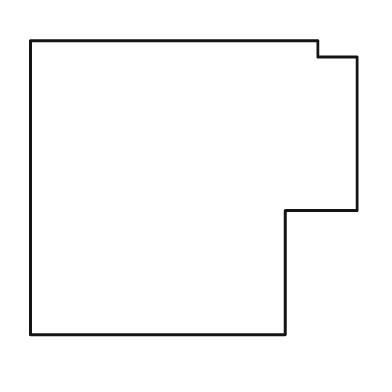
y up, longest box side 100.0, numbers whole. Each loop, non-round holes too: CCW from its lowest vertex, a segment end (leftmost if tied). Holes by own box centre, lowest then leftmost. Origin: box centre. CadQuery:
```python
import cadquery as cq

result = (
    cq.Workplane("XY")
    .moveTo(-50.0, -45.0)
    .lineTo(28.0, -45.0)
    .lineTo(28.0, -7.0)
    .lineTo(50.0, -7.0)
    .lineTo(50.0, 40.0)
    .lineTo(38.0, 40.0)
    .lineTo(38.0, 45.0)
    .lineTo(-50.0, 45.0)
    .close()
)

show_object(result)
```